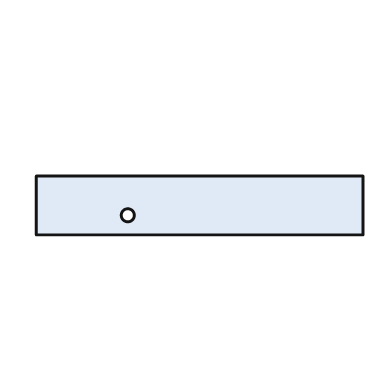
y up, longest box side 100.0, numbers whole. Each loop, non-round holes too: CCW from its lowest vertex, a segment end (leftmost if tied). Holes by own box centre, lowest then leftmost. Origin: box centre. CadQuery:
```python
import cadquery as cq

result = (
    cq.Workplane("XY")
    .moveTo(-50.0, -9.0)
    .lineTo(50.0, -9.0)
    .lineTo(50.0, 9.0)
    .lineTo(-50.0, 9.0)
    .close()
    .moveTo(-22.0, -3.0)
    .circle(2.0)
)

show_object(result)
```